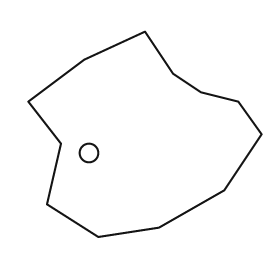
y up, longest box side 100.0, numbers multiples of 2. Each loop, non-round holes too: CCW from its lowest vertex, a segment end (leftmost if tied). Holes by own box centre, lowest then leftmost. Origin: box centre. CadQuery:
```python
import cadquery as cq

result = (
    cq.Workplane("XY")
    .moveTo(-20.0, -44.0)
    .lineTo(6.0, -40.0)
    .lineTo(34.0, -24.0)
    .lineTo(50.0, 0.0)
    .lineTo(40.0, 14.0)
    .lineTo(24.0, 18.0)
    .lineTo(12.0, 26.0)
    .lineTo(0.0, 44.0)
    .lineTo(-26.0, 32.0)
    .lineTo(-50.0, 14.0)
    .lineTo(-36.0, -4.0)
    .lineTo(-42.0, -30.0)
    .close()
    .moveTo(-24.0, -8.0)
    .circle(4.0)
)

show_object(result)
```